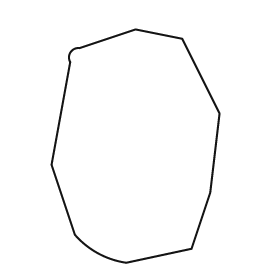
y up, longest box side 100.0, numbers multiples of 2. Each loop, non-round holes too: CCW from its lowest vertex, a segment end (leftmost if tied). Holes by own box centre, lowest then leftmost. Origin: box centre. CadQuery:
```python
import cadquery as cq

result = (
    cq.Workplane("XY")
    .moveTo(-4.0, -50.0)
    .lineTo(24.0, -44.0)
    .lineTo(32.0, -20.0)
    .lineTo(36.0, 14.0)
    .lineTo(20.0, 46.0)
    .lineTo(0.0, 50.0)
    .lineTo(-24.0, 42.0)
    .threePointArc((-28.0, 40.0), (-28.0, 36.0))
    .lineTo(-36.0, -8.0)
    .lineTo(-26.0, -38.0)
    .threePointArc((-16.0, -46.0), (-4.0, -50.0))
    .close()
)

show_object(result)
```